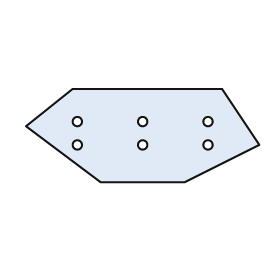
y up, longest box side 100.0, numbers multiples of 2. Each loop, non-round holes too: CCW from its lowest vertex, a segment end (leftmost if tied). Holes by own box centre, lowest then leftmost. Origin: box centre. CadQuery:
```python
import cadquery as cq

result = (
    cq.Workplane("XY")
    .moveTo(-18.0, -20.0)
    .lineTo(18.0, -20.0)
    .lineTo(50.0, -4.0)
    .lineTo(34.0, 20.0)
    .lineTo(-30.0, 20.0)
    .lineTo(-50.0, 4.0)
    .close()
    .moveTo(-28.0, -4.0)
    .circle(2.0)
    .moveTo(0.0, -4.0)
    .circle(2.0)
    .moveTo(28.0, -4.0)
    .circle(2.0)
    .moveTo(-28.0, 6.0)
    .circle(2.0)
    .moveTo(0.0, 6.0)
    .circle(2.0)
    .moveTo(28.0, 6.0)
    .circle(2.0)
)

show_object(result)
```